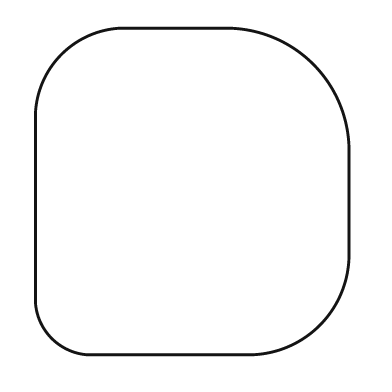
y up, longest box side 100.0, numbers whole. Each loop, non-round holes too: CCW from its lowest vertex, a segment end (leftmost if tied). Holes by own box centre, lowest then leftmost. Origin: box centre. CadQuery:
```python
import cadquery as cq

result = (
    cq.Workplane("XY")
    .moveTo(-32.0, -50.0)
    .lineTo(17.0, -50.0)
    .threePointArc((39.0, -41.0), (48.0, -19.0))
    .lineTo(48.0, 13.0)
    .threePointArc((37.0, 39.0), (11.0, 50.0))
    .lineTo(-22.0, 50.0)
    .threePointArc((-40.0, 42.0), (-48.0, 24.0))
    .lineTo(-48.0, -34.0)
    .threePointArc((-43.0, -45.0), (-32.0, -50.0))
    .close()
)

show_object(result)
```